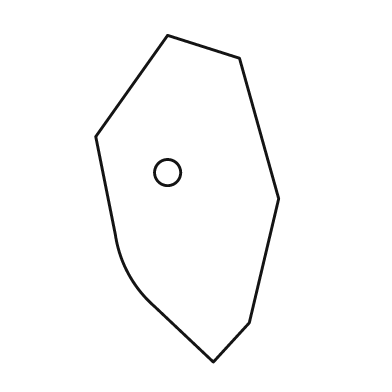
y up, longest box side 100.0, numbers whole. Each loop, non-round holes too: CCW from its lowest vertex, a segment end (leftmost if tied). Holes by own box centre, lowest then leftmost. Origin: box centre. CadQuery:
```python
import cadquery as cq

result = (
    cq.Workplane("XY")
    .moveTo(8.0, -50.0)
    .lineTo(19.0, -38.0)
    .lineTo(28.0, 0.0)
    .lineTo(16.0, 43.0)
    .lineTo(-6.0, 50.0)
    .lineTo(-28.0, 19.0)
    .lineTo(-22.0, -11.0)
    .threePointArc((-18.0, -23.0), (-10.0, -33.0))
    .close()
    .moveTo(-6.0, 8.0)
    .circle(4.0)
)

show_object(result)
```